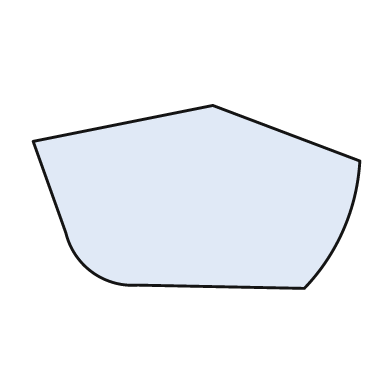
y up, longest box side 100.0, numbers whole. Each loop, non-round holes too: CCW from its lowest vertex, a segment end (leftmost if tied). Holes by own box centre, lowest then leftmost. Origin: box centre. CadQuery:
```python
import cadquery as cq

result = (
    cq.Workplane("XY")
    .moveTo(33.0, -28.0)
    .threePointArc((45.0, -10.0), (50.0, 11.0))
    .lineTo(5.0, 28.0)
    .lineTo(-50.0, 17.0)
    .lineTo(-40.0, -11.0)
    .threePointArc((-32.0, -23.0), (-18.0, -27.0))
    .close()
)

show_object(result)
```